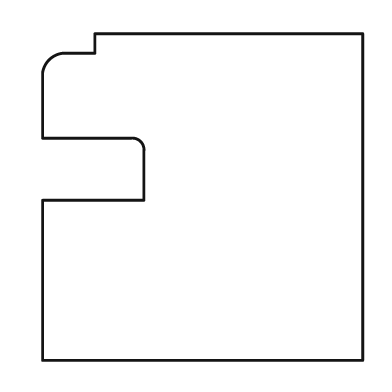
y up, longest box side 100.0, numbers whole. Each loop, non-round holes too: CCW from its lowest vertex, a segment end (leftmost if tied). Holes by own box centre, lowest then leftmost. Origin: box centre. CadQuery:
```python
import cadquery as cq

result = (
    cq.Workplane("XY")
    .moveTo(-49.0, -50.0)
    .lineTo(49.0, -50.0)
    .lineTo(49.0, 50.0)
    .lineTo(-33.0, 50.0)
    .lineTo(-33.0, 44.0)
    .lineTo(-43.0, 44.0)
    .threePointArc((-47.0, 42.0), (-49.0, 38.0))
    .lineTo(-49.0, 18.0)
    .lineTo(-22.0, 18.0)
    .threePointArc((-19.0, 17.0), (-18.0, 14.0))
    .lineTo(-18.0, -1.0)
    .lineTo(-49.0, -1.0)
    .close()
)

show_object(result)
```